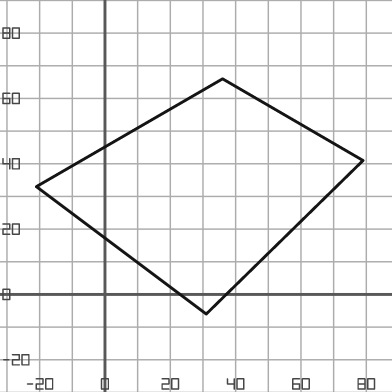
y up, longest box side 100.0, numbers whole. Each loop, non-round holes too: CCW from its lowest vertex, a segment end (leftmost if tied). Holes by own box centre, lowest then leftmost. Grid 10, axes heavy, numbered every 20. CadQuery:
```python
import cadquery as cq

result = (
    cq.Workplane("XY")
    .moveTo(31.0, -6.0)
    .lineTo(79.0, 41.0)
    .lineTo(36.0, 66.0)
    .lineTo(-21.0, 33.0)
    .close()
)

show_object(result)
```